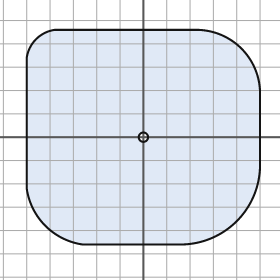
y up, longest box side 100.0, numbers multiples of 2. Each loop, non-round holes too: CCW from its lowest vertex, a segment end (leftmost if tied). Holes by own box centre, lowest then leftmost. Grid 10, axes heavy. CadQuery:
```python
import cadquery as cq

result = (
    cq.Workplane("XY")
    .moveTo(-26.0, -46.0)
    .lineTo(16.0, -46.0)
    .threePointArc((40.0, -36.0), (50.0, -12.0))
    .lineTo(50.0, 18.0)
    .threePointArc((42.0, 38.0), (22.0, 46.0))
    .lineTo(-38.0, 46.0)
    .threePointArc((-46.0, 42.0), (-50.0, 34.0))
    .lineTo(-50.0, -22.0)
    .threePointArc((-42.0, -38.0), (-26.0, -46.0))
    .close()
    .moveTo(0.0, 0.0)
    .circle(2.0)
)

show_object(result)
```